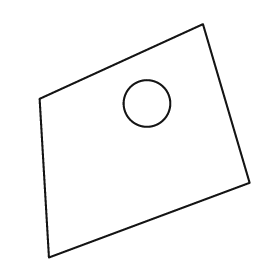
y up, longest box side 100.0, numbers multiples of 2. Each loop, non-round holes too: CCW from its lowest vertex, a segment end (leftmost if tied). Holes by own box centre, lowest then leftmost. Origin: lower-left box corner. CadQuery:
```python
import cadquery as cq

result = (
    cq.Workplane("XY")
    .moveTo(4.0, 0.0)
    .lineTo(90.0, 32.0)
    .lineTo(70.0, 100.0)
    .lineTo(0.0, 68.0)
    .close()
    .moveTo(46.0, 66.0)
    .circle(10.0)
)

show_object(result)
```